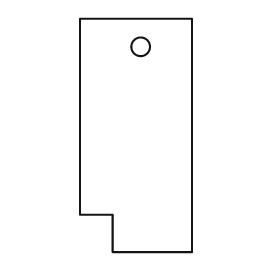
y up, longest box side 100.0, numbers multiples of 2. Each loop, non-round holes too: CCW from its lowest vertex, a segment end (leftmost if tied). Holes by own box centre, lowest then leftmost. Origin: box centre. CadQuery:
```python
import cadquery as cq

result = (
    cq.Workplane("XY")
    .moveTo(-10.0, -50.0)
    .lineTo(24.0, -50.0)
    .lineTo(24.0, 50.0)
    .lineTo(-24.0, 50.0)
    .lineTo(-24.0, -34.0)
    .lineTo(-10.0, -34.0)
    .close()
    .moveTo(2.0, 38.0)
    .circle(4.0)
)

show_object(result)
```